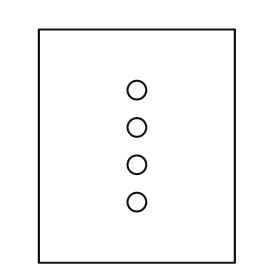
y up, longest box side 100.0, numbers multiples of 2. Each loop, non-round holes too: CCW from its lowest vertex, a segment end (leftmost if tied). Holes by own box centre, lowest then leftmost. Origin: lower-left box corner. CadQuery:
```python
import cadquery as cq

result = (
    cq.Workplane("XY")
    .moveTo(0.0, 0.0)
    .lineTo(84.0, 0.0)
    .lineTo(84.0, 100.0)
    .lineTo(0.0, 100.0)
    .close()
    .moveTo(42.0, 26.0)
    .circle(4.0)
    .moveTo(42.0, 42.0)
    .circle(4.0)
    .moveTo(42.0, 58.0)
    .circle(4.0)
    .moveTo(42.0, 74.0)
    .circle(4.0)
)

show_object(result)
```